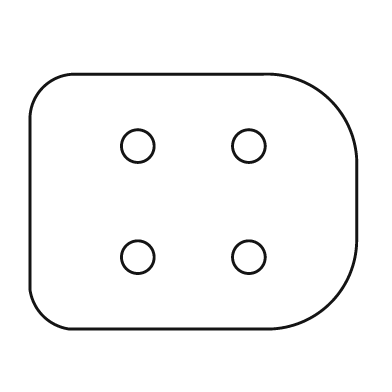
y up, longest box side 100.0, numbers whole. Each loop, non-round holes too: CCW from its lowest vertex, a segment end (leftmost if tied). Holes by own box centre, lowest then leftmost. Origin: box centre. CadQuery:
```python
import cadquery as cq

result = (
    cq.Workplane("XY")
    .moveTo(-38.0, -39.0)
    .lineTo(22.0, -39.0)
    .threePointArc((42.0, -31.0), (50.0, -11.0))
    .lineTo(50.0, 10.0)
    .threePointArc((42.0, 31.0), (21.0, 39.0))
    .lineTo(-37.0, 39.0)
    .threePointArc((-46.0, 35.0), (-50.0, 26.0))
    .lineTo(-50.0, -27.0)
    .threePointArc((-46.0, -35.0), (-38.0, -39.0))
    .close()
    .moveTo(-17.0, -17.0)
    .circle(5.0)
    .moveTo(17.0, -17.0)
    .circle(5.0)
    .moveTo(-17.0, 17.0)
    .circle(5.0)
    .moveTo(17.0, 17.0)
    .circle(5.0)
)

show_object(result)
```